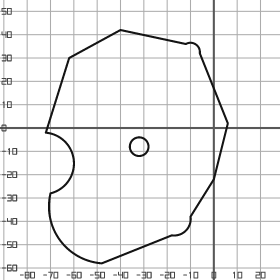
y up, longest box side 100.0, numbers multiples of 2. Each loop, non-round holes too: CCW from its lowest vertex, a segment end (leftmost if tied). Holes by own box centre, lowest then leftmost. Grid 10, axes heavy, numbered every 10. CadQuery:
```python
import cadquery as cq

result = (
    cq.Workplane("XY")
    .moveTo(-48.0, -58.0)
    .lineTo(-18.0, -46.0)
    .threePointArc((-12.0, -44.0), (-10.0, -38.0))
    .lineTo(0.0, -22.0)
    .lineTo(6.0, 2.0)
    .lineTo(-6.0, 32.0)
    .threePointArc((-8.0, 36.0), (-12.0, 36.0))
    .lineTo(-40.0, 42.0)
    .lineTo(-62.0, 30.0)
    .lineTo(-72.0, -2.0)
    .threePointArc((-60.0, -14.0), (-70.0, -28.0))
    .threePointArc((-66.0, -48.0), (-48.0, -58.0))
    .close()
    .moveTo(-32.0, -8.0)
    .circle(4.0)
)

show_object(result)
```